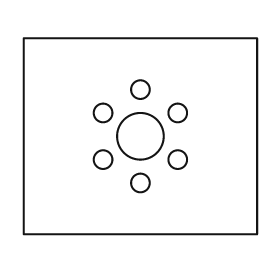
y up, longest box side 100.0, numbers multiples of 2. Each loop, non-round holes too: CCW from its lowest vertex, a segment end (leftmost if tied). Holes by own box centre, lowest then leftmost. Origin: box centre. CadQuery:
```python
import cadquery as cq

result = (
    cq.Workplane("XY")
    .moveTo(-50.0, -42.0)
    .lineTo(50.0, -42.0)
    .lineTo(50.0, 42.0)
    .lineTo(-50.0, 42.0)
    .close()
    .moveTo(0.0, -20.0)
    .circle(4.0)
    .moveTo(-16.0, -10.0)
    .circle(4.0)
    .moveTo(16.0, -10.0)
    .circle(4.0)
    .moveTo(0.0, 0.0)
    .circle(10.0)
    .moveTo(-16.0, 10.0)
    .circle(4.0)
    .moveTo(16.0, 10.0)
    .circle(4.0)
    .moveTo(0.0, 20.0)
    .circle(4.0)
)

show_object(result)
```